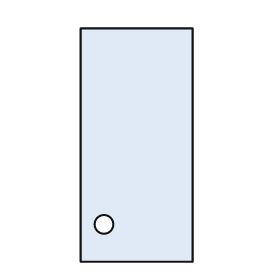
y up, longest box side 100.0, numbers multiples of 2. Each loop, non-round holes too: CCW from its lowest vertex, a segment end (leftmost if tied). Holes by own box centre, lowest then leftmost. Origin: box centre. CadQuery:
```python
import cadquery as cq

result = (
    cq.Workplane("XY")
    .moveTo(-24.0, -50.0)
    .lineTo(24.0, -50.0)
    .lineTo(24.0, 50.0)
    .lineTo(-24.0, 50.0)
    .close()
    .moveTo(-14.0, -34.0)
    .circle(4.0)
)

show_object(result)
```